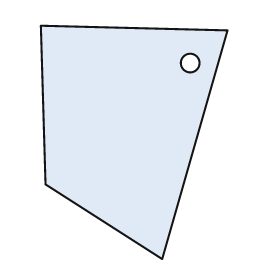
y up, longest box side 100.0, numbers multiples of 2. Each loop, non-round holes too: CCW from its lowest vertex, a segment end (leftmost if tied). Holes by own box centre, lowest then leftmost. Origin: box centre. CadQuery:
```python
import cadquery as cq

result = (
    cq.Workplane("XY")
    .moveTo(12.0, -50.0)
    .lineTo(40.0, 48.0)
    .lineTo(-40.0, 50.0)
    .lineTo(-38.0, -18.0)
    .close()
    .moveTo(24.0, 34.0)
    .circle(4.0)
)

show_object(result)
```